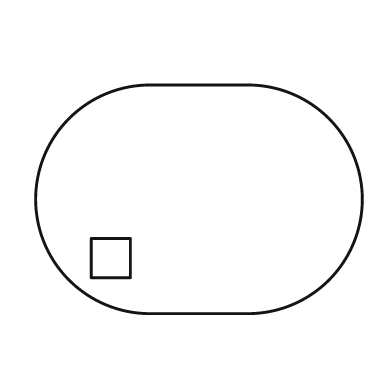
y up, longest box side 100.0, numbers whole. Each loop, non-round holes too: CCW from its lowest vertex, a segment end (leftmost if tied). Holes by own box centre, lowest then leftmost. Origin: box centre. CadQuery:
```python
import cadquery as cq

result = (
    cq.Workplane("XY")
    .moveTo(-15.0, -35.0)
    .lineTo(15.0, -35.0)
    .threePointArc((50.0, 0.0), (15.0, 35.0))
    .lineTo(-15.0, 35.0)
    .threePointArc((-50.0, 0.0), (-15.0, -35.0))
    .close()
    .moveTo(-33.0, -24.0)
    .lineTo(-21.0, -24.0)
    .lineTo(-21.0, -12.0)
    .lineTo(-33.0, -12.0)
    .close()
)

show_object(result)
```